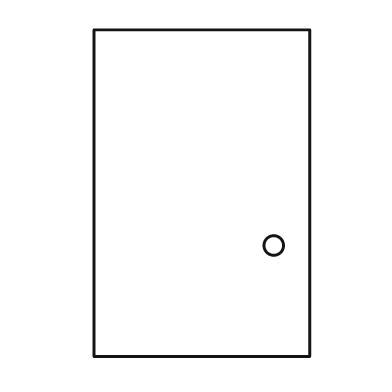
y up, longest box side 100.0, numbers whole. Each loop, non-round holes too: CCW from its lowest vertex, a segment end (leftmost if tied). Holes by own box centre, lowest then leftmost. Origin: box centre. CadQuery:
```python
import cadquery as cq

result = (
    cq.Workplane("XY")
    .moveTo(-33.0, -50.0)
    .lineTo(33.0, -50.0)
    .lineTo(33.0, 50.0)
    .lineTo(-33.0, 50.0)
    .close()
    .moveTo(22.0, -16.0)
    .circle(3.0)
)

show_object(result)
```